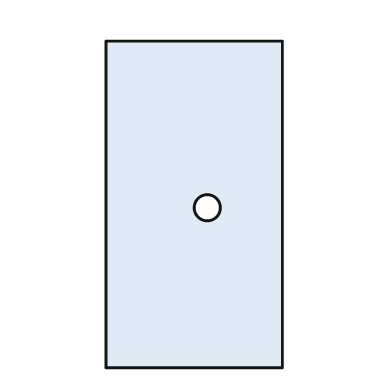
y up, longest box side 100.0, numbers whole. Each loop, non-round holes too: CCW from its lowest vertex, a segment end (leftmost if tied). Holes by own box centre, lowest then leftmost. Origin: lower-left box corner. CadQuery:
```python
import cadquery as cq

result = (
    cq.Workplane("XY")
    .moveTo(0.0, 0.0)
    .lineTo(54.0, 0.0)
    .lineTo(54.0, 100.0)
    .lineTo(0.0, 100.0)
    .close()
    .moveTo(31.0, 49.0)
    .circle(4.0)
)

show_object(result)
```